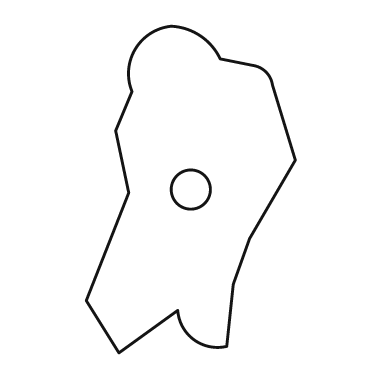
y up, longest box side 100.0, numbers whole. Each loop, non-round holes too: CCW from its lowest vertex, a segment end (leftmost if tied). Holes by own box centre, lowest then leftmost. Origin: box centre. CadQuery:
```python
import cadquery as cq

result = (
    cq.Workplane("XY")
    .moveTo(-22.0, -50.0)
    .lineTo(-4.0, -37.0)
    .threePointArc((1.0, -46.0), (11.0, -48.0))
    .lineTo(13.0, -29.0)
    .lineTo(18.0, -15.0)
    .lineTo(32.0, 9.0)
    .lineTo(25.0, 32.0)
    .threePointArc((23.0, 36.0), (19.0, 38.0))
    .lineTo(9.0, 40.0)
    .threePointArc((3.0, 47.0), (-6.0, 50.0))
    .threePointArc((-17.0, 43.0), (-18.0, 30.0))
    .lineTo(-23.0, 18.0)
    .lineTo(-19.0, -1.0)
    .lineTo(-32.0, -34.0)
    .close()
    .moveTo(0.0, 0.0)
    .circle(6.0)
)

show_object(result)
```